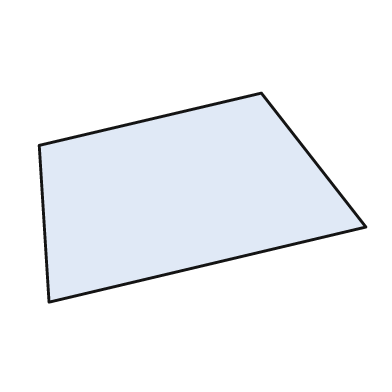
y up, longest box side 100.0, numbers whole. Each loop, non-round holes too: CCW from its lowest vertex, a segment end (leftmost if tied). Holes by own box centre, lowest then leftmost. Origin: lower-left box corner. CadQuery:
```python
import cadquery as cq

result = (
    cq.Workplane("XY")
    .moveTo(3.0, 0.0)
    .lineTo(100.0, 23.0)
    .lineTo(68.0, 64.0)
    .lineTo(0.0, 48.0)
    .close()
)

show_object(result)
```